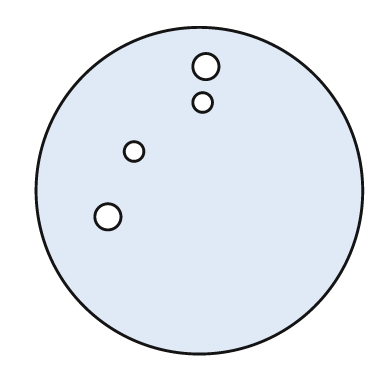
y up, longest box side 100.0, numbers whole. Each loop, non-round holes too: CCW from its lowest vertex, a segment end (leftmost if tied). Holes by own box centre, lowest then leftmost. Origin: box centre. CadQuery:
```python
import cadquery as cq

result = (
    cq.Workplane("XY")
    .moveTo(0.0, 0.0)
    .circle(50.0)
    .moveTo(-28.0, -8.0)
    .circle(4.0)
    .moveTo(-20.0, 12.0)
    .circle(3.0)
    .moveTo(1.0, 27.0)
    .circle(3.0)
    .moveTo(2.0, 38.0)
    .circle(4.0)
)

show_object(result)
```